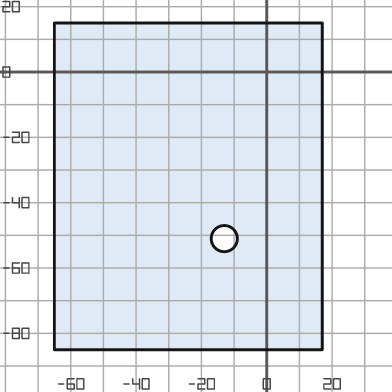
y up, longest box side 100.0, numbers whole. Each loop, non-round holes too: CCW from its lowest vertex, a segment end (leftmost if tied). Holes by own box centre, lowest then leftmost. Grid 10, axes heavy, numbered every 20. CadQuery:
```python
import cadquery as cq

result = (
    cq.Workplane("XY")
    .moveTo(-65.0, -85.0)
    .lineTo(17.0, -85.0)
    .lineTo(17.0, 15.0)
    .lineTo(-65.0, 15.0)
    .close()
    .moveTo(-13.0, -51.0)
    .circle(4.0)
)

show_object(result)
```